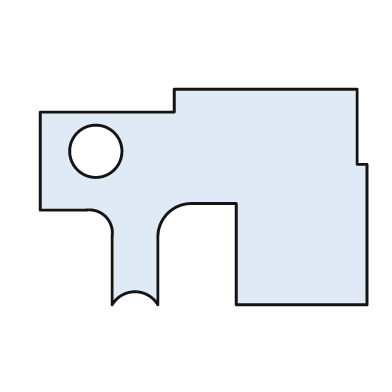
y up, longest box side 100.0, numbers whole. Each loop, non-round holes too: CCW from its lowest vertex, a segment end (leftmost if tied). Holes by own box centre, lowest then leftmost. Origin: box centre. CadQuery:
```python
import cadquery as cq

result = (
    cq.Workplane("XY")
    .moveTo(-28.0, -33.0)
    .threePointArc((-21.0, -29.0), (-14.0, -33.0))
    .lineTo(-14.0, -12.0)
    .threePointArc((-11.0, -5.0), (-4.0, -2.0))
    .lineTo(10.0, -2.0)
    .lineTo(10.0, -33.0)
    .lineTo(50.0, -33.0)
    .lineTo(50.0, 10.0)
    .lineTo(47.0, 10.0)
    .lineTo(47.0, 33.0)
    .lineTo(-9.0, 33.0)
    .lineTo(-9.0, 26.0)
    .lineTo(-50.0, 26.0)
    .lineTo(-50.0, -4.0)
    .lineTo(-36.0, -4.0)
    .threePointArc((-30.0, -6.0), (-28.0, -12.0))
    .close()
    .moveTo(-33.0, 14.0)
    .circle(8.0)
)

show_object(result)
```